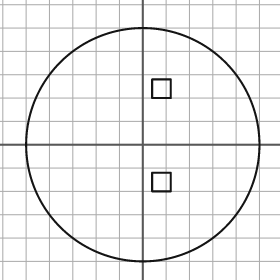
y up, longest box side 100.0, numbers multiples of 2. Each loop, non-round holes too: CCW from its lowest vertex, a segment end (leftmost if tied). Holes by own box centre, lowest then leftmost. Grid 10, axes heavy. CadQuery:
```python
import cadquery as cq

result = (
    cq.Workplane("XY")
    .moveTo(0.0, 0.0)
    .circle(50.0)
    .moveTo(4.0, -20.0)
    .lineTo(12.0, -20.0)
    .lineTo(12.0, -12.0)
    .lineTo(4.0, -12.0)
    .close()
    .moveTo(4.0, 20.0)
    .lineTo(12.0, 20.0)
    .lineTo(12.0, 28.0)
    .lineTo(4.0, 28.0)
    .close()
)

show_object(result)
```